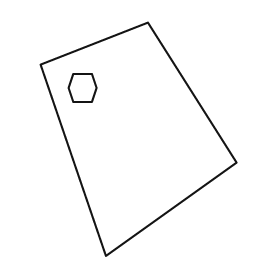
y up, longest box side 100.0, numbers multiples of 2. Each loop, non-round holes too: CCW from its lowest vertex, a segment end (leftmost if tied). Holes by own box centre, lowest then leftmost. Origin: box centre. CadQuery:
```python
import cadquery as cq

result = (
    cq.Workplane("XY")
    .moveTo(-14.0, -50.0)
    .lineTo(42.0, -10.0)
    .lineTo(4.0, 50.0)
    .lineTo(-42.0, 32.0)
    .close()
    .moveTo(-28.0, 16.0)
    .lineTo(-20.0, 16.0)
    .lineTo(-18.0, 22.0)
    .lineTo(-20.0, 28.0)
    .lineTo(-28.0, 28.0)
    .lineTo(-30.0, 22.0)
    .close()
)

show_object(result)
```